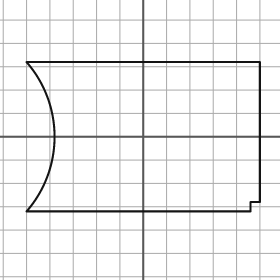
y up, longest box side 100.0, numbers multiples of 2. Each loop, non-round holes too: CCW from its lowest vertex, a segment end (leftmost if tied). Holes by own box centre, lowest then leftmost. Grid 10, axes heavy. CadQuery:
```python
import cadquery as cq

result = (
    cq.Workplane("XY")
    .moveTo(-50.0, -32.0)
    .lineTo(46.0, -32.0)
    .lineTo(46.0, -28.0)
    .lineTo(50.0, -28.0)
    .lineTo(50.0, 32.0)
    .lineTo(-50.0, 32.0)
    .threePointArc((-38.0, 0.0), (-50.0, -32.0))
    .close()
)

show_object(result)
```